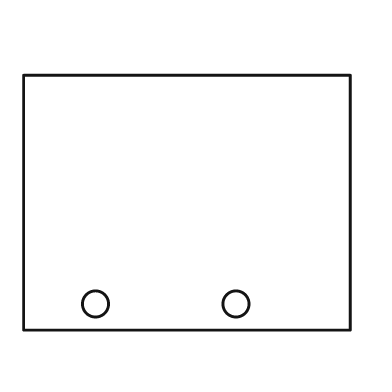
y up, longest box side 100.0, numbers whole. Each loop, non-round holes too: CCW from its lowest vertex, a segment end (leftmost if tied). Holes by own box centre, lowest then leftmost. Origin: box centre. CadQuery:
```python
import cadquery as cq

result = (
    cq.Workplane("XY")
    .moveTo(-50.0, -39.0)
    .lineTo(50.0, -39.0)
    .lineTo(50.0, 39.0)
    .lineTo(-50.0, 39.0)
    .close()
    .moveTo(-28.0, -31.0)
    .circle(4.0)
    .moveTo(15.0, -31.0)
    .circle(4.0)
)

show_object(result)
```